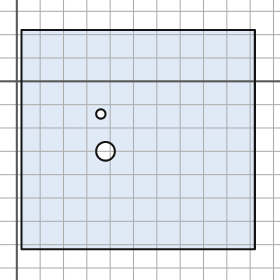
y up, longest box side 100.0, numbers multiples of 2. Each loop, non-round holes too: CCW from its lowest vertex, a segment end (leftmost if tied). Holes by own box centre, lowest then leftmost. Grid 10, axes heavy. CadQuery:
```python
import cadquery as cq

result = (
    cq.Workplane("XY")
    .moveTo(2.0, -72.0)
    .lineTo(102.0, -72.0)
    .lineTo(102.0, 22.0)
    .lineTo(2.0, 22.0)
    .close()
    .moveTo(38.0, -30.0)
    .circle(4.0)
    .moveTo(36.0, -14.0)
    .circle(2.0)
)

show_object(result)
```